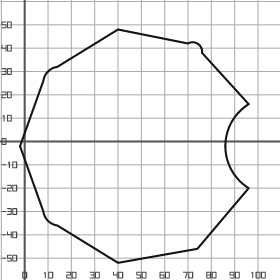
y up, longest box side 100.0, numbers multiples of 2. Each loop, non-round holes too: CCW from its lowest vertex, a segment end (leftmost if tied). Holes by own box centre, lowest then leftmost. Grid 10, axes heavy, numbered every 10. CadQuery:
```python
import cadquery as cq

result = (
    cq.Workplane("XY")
    .moveTo(40.0, -52.0)
    .lineTo(74.0, -46.0)
    .lineTo(96.0, -20.0)
    .threePointArc((86.0, -2.0), (96.0, 16.0))
    .lineTo(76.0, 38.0)
    .threePointArc((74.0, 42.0), (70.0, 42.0))
    .lineTo(40.0, 48.0)
    .lineTo(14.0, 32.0)
    .threePointArc((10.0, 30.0), (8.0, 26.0))
    .lineTo(-2.0, -2.0)
    .lineTo(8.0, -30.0)
    .threePointArc((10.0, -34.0), (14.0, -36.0))
    .close()
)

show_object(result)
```